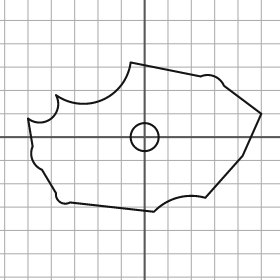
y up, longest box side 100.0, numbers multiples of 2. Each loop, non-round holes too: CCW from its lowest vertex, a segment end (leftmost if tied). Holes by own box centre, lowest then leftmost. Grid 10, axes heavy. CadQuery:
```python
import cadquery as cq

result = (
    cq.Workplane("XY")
    .moveTo(4.0, -32.0)
    .threePointArc((14.0, -26.0), (26.0, -26.0))
    .lineTo(42.0, -8.0)
    .lineTo(50.0, 10.0)
    .lineTo(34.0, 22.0)
    .threePointArc((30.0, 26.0), (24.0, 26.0))
    .lineTo(-6.0, 32.0)
    .threePointArc((-18.0, 16.0), (-38.0, 18.0))
    .threePointArc((-40.0, 8.0), (-50.0, 8.0))
    .lineTo(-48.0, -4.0)
    .threePointArc((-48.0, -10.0), (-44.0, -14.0))
    .lineTo(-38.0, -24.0)
    .threePointArc((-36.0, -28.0), (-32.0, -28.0))
    .close()
    .moveTo(0.0, 0.0)
    .circle(6.0)
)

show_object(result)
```